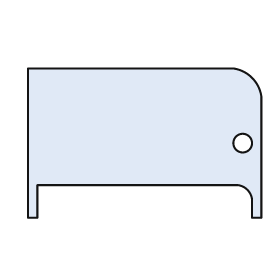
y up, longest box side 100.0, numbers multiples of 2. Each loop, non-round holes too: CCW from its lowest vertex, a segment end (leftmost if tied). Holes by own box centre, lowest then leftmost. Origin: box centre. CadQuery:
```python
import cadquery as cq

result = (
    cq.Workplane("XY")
    .moveTo(-50.0, -32.0)
    .lineTo(-46.0, -32.0)
    .lineTo(-46.0, -18.0)
    .lineTo(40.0, -18.0)
    .threePointArc((44.0, -20.0), (46.0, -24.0))
    .lineTo(46.0, -32.0)
    .lineTo(50.0, -32.0)
    .lineTo(50.0, 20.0)
    .threePointArc((46.0, 28.0), (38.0, 32.0))
    .lineTo(-50.0, 32.0)
    .close()
    .moveTo(42.0, 0.0)
    .circle(4.0)
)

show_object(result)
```